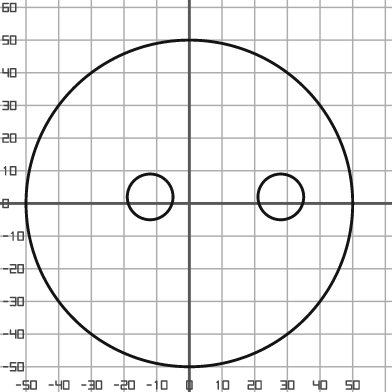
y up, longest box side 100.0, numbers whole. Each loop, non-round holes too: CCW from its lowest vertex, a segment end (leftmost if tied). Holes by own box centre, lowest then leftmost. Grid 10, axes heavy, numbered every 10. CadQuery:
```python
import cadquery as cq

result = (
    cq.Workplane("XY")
    .moveTo(0.0, 0.0)
    .circle(50.0)
    .moveTo(-12.0, 2.0)
    .circle(7.0)
    .moveTo(28.0, 2.0)
    .circle(7.0)
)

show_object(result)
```